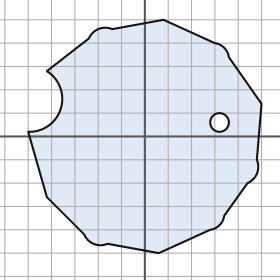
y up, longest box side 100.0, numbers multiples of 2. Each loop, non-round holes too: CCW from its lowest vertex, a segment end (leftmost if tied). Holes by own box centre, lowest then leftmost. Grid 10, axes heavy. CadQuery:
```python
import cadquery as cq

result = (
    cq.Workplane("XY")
    .moveTo(6.0, -50.0)
    .lineTo(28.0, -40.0)
    .threePointArc((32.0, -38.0), (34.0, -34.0))
    .lineTo(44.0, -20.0)
    .threePointArc((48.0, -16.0), (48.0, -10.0))
    .lineTo(50.0, 14.0)
    .lineTo(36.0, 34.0)
    .threePointArc((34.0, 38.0), (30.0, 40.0))
    .lineTo(8.0, 50.0)
    .lineTo(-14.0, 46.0)
    .threePointArc((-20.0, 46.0), (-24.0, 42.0))
    .lineTo(-42.0, 28.0)
    .threePointArc((-36.0, 12.0), (-50.0, 2.0))
    .lineTo(-42.0, -26.0)
    .lineTo(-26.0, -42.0)
    .threePointArc((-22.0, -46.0), (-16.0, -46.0))
    .close()
    .moveTo(32.0, 6.0)
    .circle(4.0)
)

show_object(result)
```